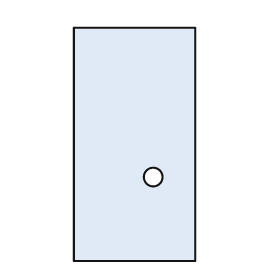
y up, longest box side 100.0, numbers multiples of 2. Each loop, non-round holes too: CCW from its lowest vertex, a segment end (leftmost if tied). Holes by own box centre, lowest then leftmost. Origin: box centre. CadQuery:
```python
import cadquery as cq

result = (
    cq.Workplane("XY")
    .moveTo(-26.0, -50.0)
    .lineTo(26.0, -50.0)
    .lineTo(26.0, 50.0)
    .lineTo(-26.0, 50.0)
    .close()
    .moveTo(8.0, -14.0)
    .circle(4.0)
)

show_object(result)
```